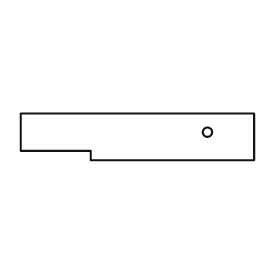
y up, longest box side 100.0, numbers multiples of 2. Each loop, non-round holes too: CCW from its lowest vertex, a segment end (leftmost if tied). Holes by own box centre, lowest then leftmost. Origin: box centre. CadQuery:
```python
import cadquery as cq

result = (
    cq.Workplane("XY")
    .moveTo(-20.0, -10.0)
    .lineTo(50.0, -10.0)
    .lineTo(50.0, 10.0)
    .lineTo(-50.0, 10.0)
    .lineTo(-50.0, -6.0)
    .lineTo(-20.0, -6.0)
    .close()
    .moveTo(30.0, 2.0)
    .circle(2.0)
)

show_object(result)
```